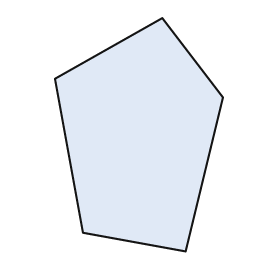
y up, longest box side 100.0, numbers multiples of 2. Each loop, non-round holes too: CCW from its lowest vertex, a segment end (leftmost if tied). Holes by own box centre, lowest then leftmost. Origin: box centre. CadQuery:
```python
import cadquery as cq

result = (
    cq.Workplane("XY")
    .moveTo(20.0, -50.0)
    .lineTo(36.0, 16.0)
    .lineTo(10.0, 50.0)
    .lineTo(-36.0, 24.0)
    .lineTo(-24.0, -42.0)
    .close()
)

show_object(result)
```